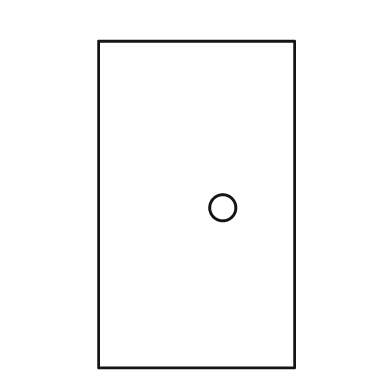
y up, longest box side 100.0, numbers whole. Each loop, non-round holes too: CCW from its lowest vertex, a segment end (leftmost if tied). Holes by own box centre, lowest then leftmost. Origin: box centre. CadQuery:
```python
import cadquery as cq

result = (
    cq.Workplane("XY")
    .moveTo(-30.0, -50.0)
    .lineTo(30.0, -50.0)
    .lineTo(30.0, 50.0)
    .lineTo(-30.0, 50.0)
    .close()
    .moveTo(8.0, -1.0)
    .circle(4.0)
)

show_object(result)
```